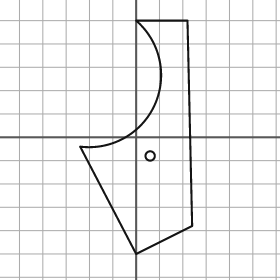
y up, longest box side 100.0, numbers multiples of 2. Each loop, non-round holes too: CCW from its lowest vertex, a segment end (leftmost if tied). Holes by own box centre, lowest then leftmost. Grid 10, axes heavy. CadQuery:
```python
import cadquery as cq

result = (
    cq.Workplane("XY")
    .moveTo(0.0, -50.0)
    .lineTo(24.0, -38.0)
    .lineTo(22.0, 50.0)
    .lineTo(0.0, 50.0)
    .threePointArc((8.0, 14.0), (-24.0, -4.0))
    .close()
    .moveTo(6.0, -8.0)
    .circle(2.0)
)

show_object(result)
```